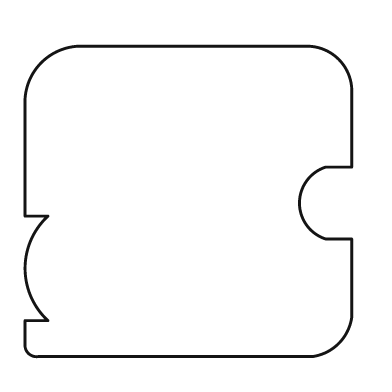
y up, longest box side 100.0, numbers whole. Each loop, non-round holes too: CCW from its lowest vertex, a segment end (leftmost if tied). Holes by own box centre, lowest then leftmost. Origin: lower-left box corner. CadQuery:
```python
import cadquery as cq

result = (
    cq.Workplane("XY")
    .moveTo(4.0, 0.0)
    .lineTo(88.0, 0.0)
    .threePointArc((96.0, 4.0), (100.0, 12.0))
    .lineTo(100.0, 36.0)
    .lineTo(92.0, 36.0)
    .threePointArc((84.0, 47.0), (92.0, 58.0))
    .lineTo(100.0, 58.0)
    .lineTo(100.0, 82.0)
    .threePointArc((96.0, 91.0), (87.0, 95.0))
    .lineTo(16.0, 95.0)
    .threePointArc((5.0, 90.0), (0.0, 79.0))
    .lineTo(0.0, 43.0)
    .lineTo(7.0, 43.0)
    .threePointArc((0.0, 27.0), (7.0, 11.0))
    .lineTo(0.0, 11.0)
    .lineTo(0.0, 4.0)
    .threePointArc((1.0, 1.0), (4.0, 0.0))
    .close()
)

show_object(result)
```